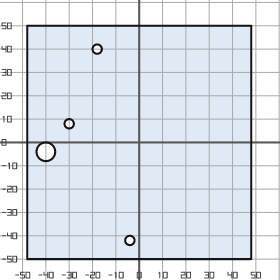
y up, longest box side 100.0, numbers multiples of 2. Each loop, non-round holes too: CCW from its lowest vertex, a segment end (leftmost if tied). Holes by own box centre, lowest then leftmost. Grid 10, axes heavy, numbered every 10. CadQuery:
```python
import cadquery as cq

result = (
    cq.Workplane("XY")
    .moveTo(-48.0, -50.0)
    .lineTo(48.0, -50.0)
    .lineTo(48.0, 50.0)
    .lineTo(-48.0, 50.0)
    .close()
    .moveTo(-4.0, -42.0)
    .circle(2.0)
    .moveTo(-40.0, -4.0)
    .circle(4.0)
    .moveTo(-30.0, 8.0)
    .circle(2.0)
    .moveTo(-18.0, 40.0)
    .circle(2.0)
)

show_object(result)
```